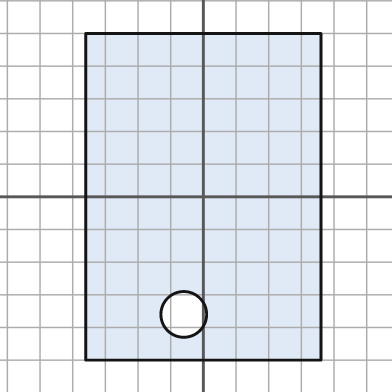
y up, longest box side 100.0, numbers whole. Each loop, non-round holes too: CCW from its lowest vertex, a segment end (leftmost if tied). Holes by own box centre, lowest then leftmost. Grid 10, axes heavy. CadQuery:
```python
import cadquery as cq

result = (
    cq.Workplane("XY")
    .moveTo(-36.0, -50.0)
    .lineTo(36.0, -50.0)
    .lineTo(36.0, 50.0)
    .lineTo(-36.0, 50.0)
    .close()
    .moveTo(-6.0, -36.0)
    .circle(7.0)
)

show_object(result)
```